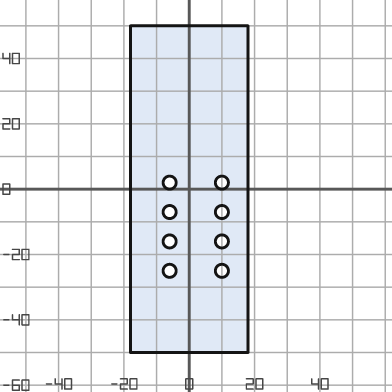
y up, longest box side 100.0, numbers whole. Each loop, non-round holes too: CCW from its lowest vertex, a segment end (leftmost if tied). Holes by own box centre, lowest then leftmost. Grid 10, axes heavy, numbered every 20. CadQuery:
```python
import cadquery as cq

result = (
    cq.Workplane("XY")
    .moveTo(-18.0, -50.0)
    .lineTo(18.0, -50.0)
    .lineTo(18.0, 50.0)
    .lineTo(-18.0, 50.0)
    .close()
    .moveTo(-6.0, -25.0)
    .circle(2.0)
    .moveTo(10.0, -25.0)
    .circle(2.0)
    .moveTo(-6.0, -16.0)
    .circle(2.0)
    .moveTo(10.0, -16.0)
    .circle(2.0)
    .moveTo(-6.0, -7.0)
    .circle(2.0)
    .moveTo(10.0, -7.0)
    .circle(2.0)
    .moveTo(-6.0, 2.0)
    .circle(2.0)
    .moveTo(10.0, 2.0)
    .circle(2.0)
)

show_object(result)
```